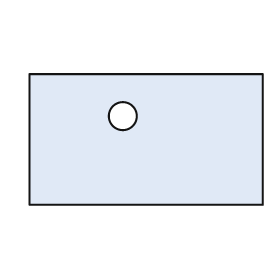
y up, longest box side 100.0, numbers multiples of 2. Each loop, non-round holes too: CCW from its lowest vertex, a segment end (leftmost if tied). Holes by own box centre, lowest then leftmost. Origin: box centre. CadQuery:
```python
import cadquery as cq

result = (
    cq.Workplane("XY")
    .moveTo(-50.0, -28.0)
    .lineTo(50.0, -28.0)
    .lineTo(50.0, 28.0)
    .lineTo(-50.0, 28.0)
    .close()
    .moveTo(-10.0, 10.0)
    .circle(6.0)
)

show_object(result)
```